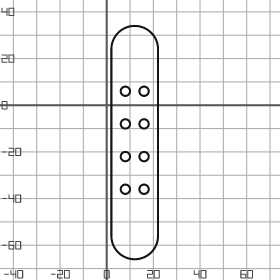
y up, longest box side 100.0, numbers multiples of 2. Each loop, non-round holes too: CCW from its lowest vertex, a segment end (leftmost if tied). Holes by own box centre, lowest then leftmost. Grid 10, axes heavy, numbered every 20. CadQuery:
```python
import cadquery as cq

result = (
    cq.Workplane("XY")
    .moveTo(2.0, -56.0)
    .threePointArc((12.0, -66.0), (22.0, -56.0))
    .lineTo(22.0, 24.0)
    .threePointArc((12.0, 34.0), (2.0, 24.0))
    .close()
    .moveTo(8.0, -36.0)
    .circle(2.0)
    .moveTo(16.0, -36.0)
    .circle(2.0)
    .moveTo(8.0, -22.0)
    .circle(2.0)
    .moveTo(16.0, -22.0)
    .circle(2.0)
    .moveTo(8.0, -8.0)
    .circle(2.0)
    .moveTo(16.0, -8.0)
    .circle(2.0)
    .moveTo(8.0, 6.0)
    .circle(2.0)
    .moveTo(16.0, 6.0)
    .circle(2.0)
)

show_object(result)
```